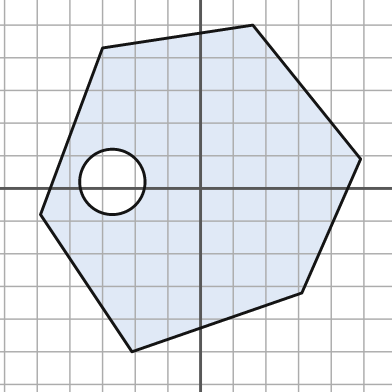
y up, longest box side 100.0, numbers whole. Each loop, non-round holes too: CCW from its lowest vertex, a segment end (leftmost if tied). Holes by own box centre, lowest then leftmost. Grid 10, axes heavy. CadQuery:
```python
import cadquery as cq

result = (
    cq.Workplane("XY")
    .moveTo(-21.0, -50.0)
    .lineTo(31.0, -32.0)
    .lineTo(49.0, 9.0)
    .lineTo(16.0, 50.0)
    .lineTo(-30.0, 43.0)
    .lineTo(-49.0, -8.0)
    .close()
    .moveTo(-27.0, 2.0)
    .circle(10.0)
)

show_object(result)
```